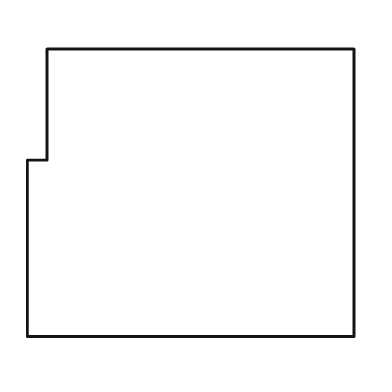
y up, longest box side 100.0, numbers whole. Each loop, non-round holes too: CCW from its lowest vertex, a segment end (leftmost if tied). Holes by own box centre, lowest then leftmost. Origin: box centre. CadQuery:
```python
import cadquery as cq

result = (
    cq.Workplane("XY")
    .moveTo(-50.0, -44.0)
    .lineTo(50.0, -44.0)
    .lineTo(50.0, 44.0)
    .lineTo(-44.0, 44.0)
    .lineTo(-44.0, 10.0)
    .lineTo(-50.0, 10.0)
    .close()
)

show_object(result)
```